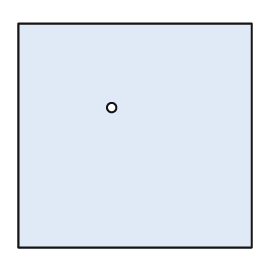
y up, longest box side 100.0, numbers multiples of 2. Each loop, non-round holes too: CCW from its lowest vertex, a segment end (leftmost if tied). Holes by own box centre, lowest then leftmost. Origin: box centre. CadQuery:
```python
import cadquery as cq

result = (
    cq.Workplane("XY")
    .moveTo(-50.0, -48.0)
    .lineTo(50.0, -48.0)
    .lineTo(50.0, 48.0)
    .lineTo(-50.0, 48.0)
    .close()
    .moveTo(-10.0, 12.0)
    .circle(2.0)
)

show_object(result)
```